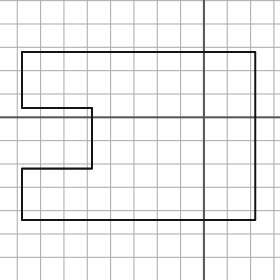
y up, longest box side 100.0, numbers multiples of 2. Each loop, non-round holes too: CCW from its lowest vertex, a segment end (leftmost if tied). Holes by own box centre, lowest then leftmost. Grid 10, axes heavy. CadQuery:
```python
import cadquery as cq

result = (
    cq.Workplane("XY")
    .moveTo(-78.0, -44.0)
    .lineTo(22.0, -44.0)
    .lineTo(22.0, 28.0)
    .lineTo(-78.0, 28.0)
    .lineTo(-78.0, 4.0)
    .lineTo(-48.0, 4.0)
    .lineTo(-48.0, -22.0)
    .lineTo(-78.0, -22.0)
    .close()
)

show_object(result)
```